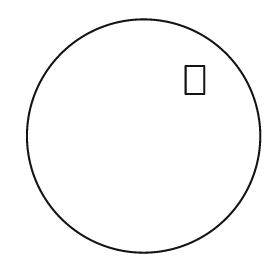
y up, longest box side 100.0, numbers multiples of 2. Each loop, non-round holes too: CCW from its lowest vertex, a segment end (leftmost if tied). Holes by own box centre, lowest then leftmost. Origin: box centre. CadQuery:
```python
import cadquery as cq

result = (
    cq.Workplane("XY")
    .moveTo(0.0, 0.0)
    .circle(50.0)
    .moveTo(18.0, 18.0)
    .lineTo(26.0, 18.0)
    .lineTo(26.0, 30.0)
    .lineTo(18.0, 30.0)
    .close()
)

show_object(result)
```